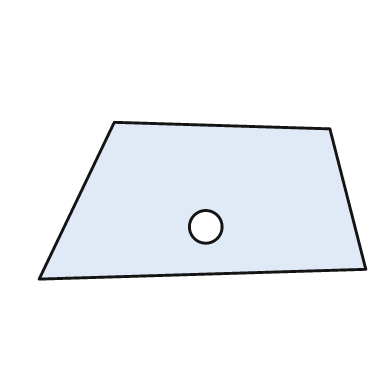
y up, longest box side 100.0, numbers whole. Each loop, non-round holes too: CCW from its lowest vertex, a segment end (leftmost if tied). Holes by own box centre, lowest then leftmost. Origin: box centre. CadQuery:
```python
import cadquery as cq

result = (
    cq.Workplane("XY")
    .moveTo(-50.0, -24.0)
    .lineTo(50.0, -21.0)
    .lineTo(39.0, 22.0)
    .lineTo(-27.0, 24.0)
    .close()
    .moveTo(1.0, -8.0)
    .circle(5.0)
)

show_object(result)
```